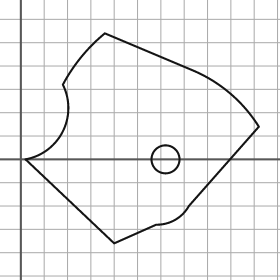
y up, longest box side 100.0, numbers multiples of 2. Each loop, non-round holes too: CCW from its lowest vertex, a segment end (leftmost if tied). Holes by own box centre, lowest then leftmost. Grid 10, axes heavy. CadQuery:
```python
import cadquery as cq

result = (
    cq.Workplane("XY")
    .moveTo(40.0, -36.0)
    .lineTo(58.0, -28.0)
    .threePointArc((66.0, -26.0), (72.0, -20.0))
    .lineTo(102.0, 14.0)
    .threePointArc((90.0, 28.0), (74.0, 38.0))
    .lineTo(36.0, 54.0)
    .threePointArc((26.0, 44.0), (18.0, 32.0))
    .threePointArc((18.0, 12.0), (2.0, 0.0))
    .close()
    .moveTo(62.0, 0.0)
    .circle(6.0)
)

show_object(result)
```